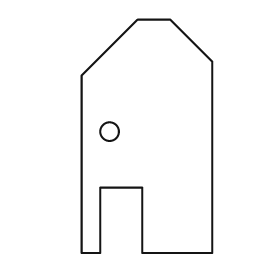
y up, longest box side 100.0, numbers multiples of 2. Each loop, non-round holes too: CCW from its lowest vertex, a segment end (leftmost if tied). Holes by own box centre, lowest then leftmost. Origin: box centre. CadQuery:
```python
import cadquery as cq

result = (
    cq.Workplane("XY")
    .moveTo(-28.0, -50.0)
    .lineTo(-20.0, -50.0)
    .lineTo(-20.0, -22.0)
    .lineTo(-2.0, -22.0)
    .lineTo(-2.0, -50.0)
    .lineTo(28.0, -50.0)
    .lineTo(28.0, 32.0)
    .lineTo(10.0, 50.0)
    .lineTo(-4.0, 50.0)
    .lineTo(-28.0, 26.0)
    .close()
    .moveTo(-16.0, 2.0)
    .circle(4.0)
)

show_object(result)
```